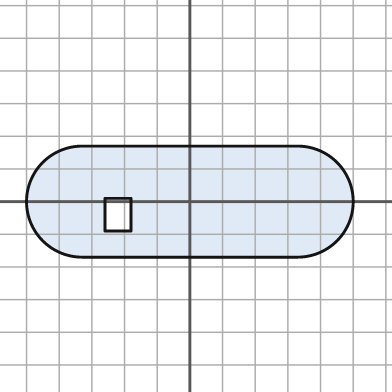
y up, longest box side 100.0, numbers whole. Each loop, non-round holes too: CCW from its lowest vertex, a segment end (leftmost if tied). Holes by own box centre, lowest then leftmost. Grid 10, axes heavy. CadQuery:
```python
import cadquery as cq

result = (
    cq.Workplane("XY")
    .moveTo(-33.0, -17.0)
    .lineTo(33.0, -17.0)
    .threePointArc((50.0, 0.0), (33.0, 17.0))
    .lineTo(-33.0, 17.0)
    .threePointArc((-50.0, 0.0), (-33.0, -17.0))
    .close()
    .moveTo(-26.0, -9.0)
    .lineTo(-18.0, -9.0)
    .lineTo(-18.0, 1.0)
    .lineTo(-26.0, 1.0)
    .close()
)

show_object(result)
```